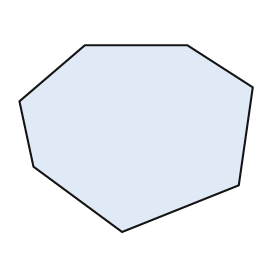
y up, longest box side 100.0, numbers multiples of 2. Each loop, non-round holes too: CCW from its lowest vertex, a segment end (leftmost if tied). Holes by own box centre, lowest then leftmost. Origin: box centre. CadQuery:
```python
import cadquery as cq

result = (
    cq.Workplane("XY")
    .moveTo(-6.0, -40.0)
    .lineTo(44.0, -20.0)
    .lineTo(50.0, 22.0)
    .lineTo(22.0, 40.0)
    .lineTo(-22.0, 40.0)
    .lineTo(-50.0, 16.0)
    .lineTo(-44.0, -12.0)
    .close()
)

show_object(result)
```